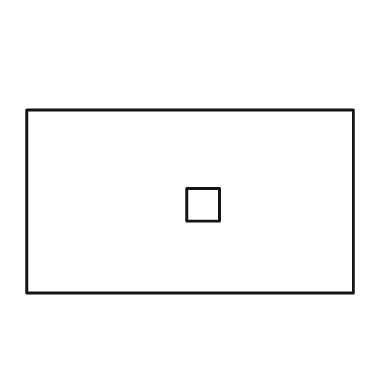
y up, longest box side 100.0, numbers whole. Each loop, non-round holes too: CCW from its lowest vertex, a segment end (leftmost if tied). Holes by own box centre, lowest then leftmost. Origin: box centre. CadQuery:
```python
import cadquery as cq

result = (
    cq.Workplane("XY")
    .moveTo(-50.0, -28.0)
    .lineTo(50.0, -28.0)
    .lineTo(50.0, 28.0)
    .lineTo(-50.0, 28.0)
    .close()
    .moveTo(-1.0, -6.0)
    .lineTo(9.0, -6.0)
    .lineTo(9.0, 4.0)
    .lineTo(-1.0, 4.0)
    .close()
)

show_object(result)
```